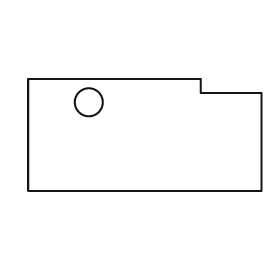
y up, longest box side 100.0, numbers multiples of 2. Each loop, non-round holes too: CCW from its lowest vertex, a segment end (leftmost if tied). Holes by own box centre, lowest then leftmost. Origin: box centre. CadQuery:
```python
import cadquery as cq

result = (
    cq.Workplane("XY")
    .moveTo(-50.0, -24.0)
    .lineTo(50.0, -24.0)
    .lineTo(50.0, 18.0)
    .lineTo(24.0, 18.0)
    .lineTo(24.0, 24.0)
    .lineTo(-50.0, 24.0)
    .close()
    .moveTo(-24.0, 14.0)
    .circle(6.0)
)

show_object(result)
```